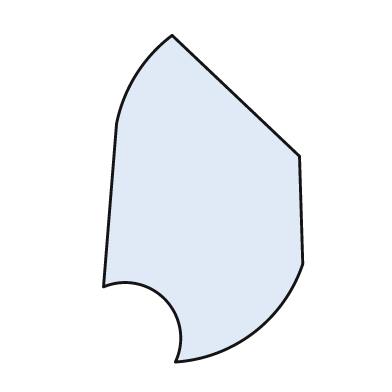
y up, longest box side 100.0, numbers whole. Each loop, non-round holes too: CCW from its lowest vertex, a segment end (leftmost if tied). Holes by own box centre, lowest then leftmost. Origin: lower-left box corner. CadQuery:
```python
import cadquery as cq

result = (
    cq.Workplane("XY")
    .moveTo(22.0, 0.0)
    .threePointArc((46.0, 9.0), (61.0, 30.0))
    .lineTo(60.0, 63.0)
    .lineTo(21.0, 100.0)
    .threePointArc((10.0, 88.0), (4.0, 73.0))
    .lineTo(0.0, 23.0)
    .threePointArc((19.0, 19.0), (22.0, 0.0))
    .close()
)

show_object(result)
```